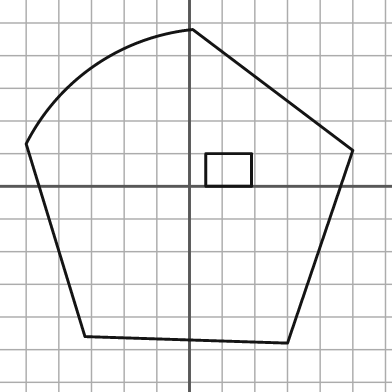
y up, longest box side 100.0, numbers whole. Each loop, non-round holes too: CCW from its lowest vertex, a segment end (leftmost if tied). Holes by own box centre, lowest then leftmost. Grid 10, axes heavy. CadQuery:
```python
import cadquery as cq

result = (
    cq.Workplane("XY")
    .moveTo(30.0, -48.0)
    .lineTo(50.0, 11.0)
    .lineTo(1.0, 48.0)
    .threePointArc((-29.0, 37.0), (-50.0, 13.0))
    .lineTo(-32.0, -46.0)
    .close()
    .moveTo(5.0, 0.0)
    .lineTo(19.0, 0.0)
    .lineTo(19.0, 10.0)
    .lineTo(5.0, 10.0)
    .close()
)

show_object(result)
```